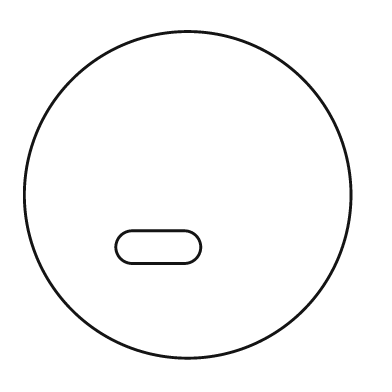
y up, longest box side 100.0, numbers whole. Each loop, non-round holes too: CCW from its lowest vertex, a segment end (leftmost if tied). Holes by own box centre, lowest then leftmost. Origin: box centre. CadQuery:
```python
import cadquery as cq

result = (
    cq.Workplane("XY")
    .moveTo(0.0, 0.0)
    .circle(50.0)
    .moveTo(-17.0, -21.0)
    .lineTo(-1.0, -21.0)
    .threePointArc((4.0, -16.0), (-1.0, -11.0))
    .lineTo(-17.0, -11.0)
    .threePointArc((-22.0, -16.0), (-17.0, -21.0))
    .close()
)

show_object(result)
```